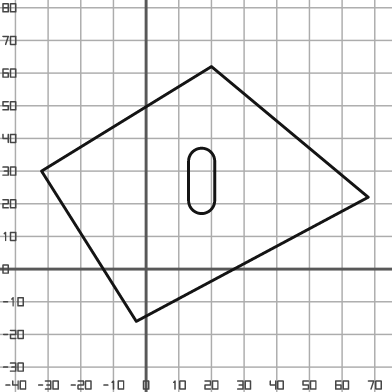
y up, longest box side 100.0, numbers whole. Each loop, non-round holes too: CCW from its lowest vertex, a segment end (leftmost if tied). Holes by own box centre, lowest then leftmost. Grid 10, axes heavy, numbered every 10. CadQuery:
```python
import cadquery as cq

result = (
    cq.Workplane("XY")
    .moveTo(-3.0, -16.0)
    .lineTo(68.0, 22.0)
    .lineTo(20.0, 62.0)
    .lineTo(-32.0, 30.0)
    .close()
    .moveTo(13.0, 21.0)
    .threePointArc((17.0, 17.0), (21.0, 21.0))
    .lineTo(21.0, 33.0)
    .threePointArc((17.0, 37.0), (13.0, 33.0))
    .close()
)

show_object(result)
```